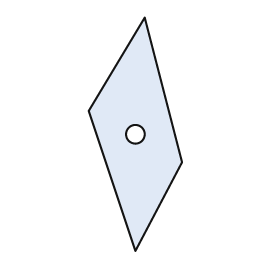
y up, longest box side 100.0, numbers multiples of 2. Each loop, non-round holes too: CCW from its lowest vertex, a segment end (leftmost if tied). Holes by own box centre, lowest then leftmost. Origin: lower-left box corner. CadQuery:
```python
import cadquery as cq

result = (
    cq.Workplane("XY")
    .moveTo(20.0, 0.0)
    .lineTo(40.0, 38.0)
    .lineTo(24.0, 100.0)
    .lineTo(0.0, 60.0)
    .close()
    .moveTo(20.0, 50.0)
    .circle(4.0)
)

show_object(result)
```